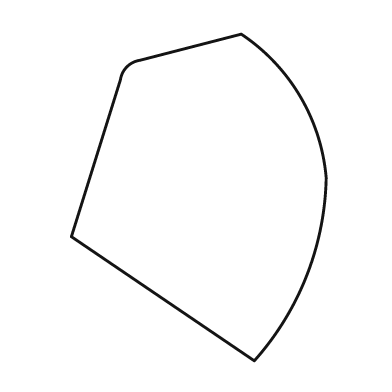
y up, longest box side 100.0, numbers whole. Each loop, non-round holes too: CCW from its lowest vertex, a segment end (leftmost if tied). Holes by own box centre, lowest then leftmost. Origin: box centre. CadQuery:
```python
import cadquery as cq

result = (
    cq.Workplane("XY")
    .moveTo(17.0, -50.0)
    .threePointArc((33.0, -24.0), (39.0, 6.0))
    .threePointArc((31.0, 31.0), (13.0, 50.0))
    .lineTo(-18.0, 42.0)
    .threePointArc((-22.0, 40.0), (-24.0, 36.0))
    .lineTo(-39.0, -12.0)
    .close()
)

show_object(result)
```